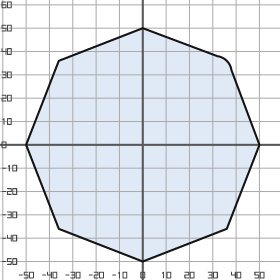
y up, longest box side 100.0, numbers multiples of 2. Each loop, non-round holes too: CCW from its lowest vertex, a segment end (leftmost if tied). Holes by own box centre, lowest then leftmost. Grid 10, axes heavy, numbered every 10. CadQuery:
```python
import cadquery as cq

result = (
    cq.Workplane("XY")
    .moveTo(0.0, -50.0)
    .lineTo(36.0, -36.0)
    .lineTo(50.0, 0.0)
    .lineTo(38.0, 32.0)
    .threePointArc((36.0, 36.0), (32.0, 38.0))
    .lineTo(0.0, 50.0)
    .lineTo(-36.0, 36.0)
    .lineTo(-50.0, 0.0)
    .lineTo(-36.0, -36.0)
    .close()
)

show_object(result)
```